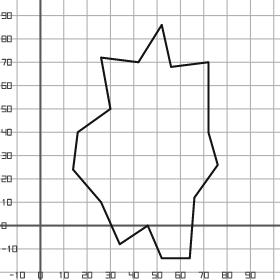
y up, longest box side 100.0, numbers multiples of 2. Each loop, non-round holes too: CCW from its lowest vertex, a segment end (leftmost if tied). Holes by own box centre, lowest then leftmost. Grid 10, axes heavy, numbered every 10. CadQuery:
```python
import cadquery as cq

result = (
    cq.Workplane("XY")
    .moveTo(52.0, -14.0)
    .lineTo(64.0, -14.0)
    .lineTo(66.0, 12.0)
    .lineTo(76.0, 26.0)
    .lineTo(72.0, 40.0)
    .lineTo(72.0, 70.0)
    .lineTo(56.0, 68.0)
    .lineTo(52.0, 86.0)
    .lineTo(42.0, 70.0)
    .lineTo(26.0, 72.0)
    .lineTo(30.0, 50.0)
    .lineTo(16.0, 40.0)
    .lineTo(14.0, 24.0)
    .lineTo(26.0, 10.0)
    .lineTo(34.0, -8.0)
    .lineTo(46.0, 0.0)
    .close()
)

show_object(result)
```